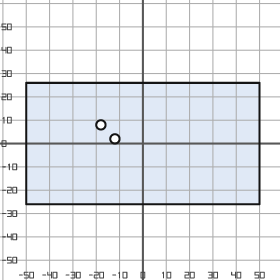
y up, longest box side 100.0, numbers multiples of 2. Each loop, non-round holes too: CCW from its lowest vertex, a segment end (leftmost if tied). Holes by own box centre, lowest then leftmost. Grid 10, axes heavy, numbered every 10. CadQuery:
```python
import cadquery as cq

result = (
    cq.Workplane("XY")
    .moveTo(-50.0, -26.0)
    .lineTo(50.0, -26.0)
    .lineTo(50.0, 26.0)
    .lineTo(-50.0, 26.0)
    .close()
    .moveTo(-12.0, 2.0)
    .circle(2.0)
    .moveTo(-18.0, 8.0)
    .circle(2.0)
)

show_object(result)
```